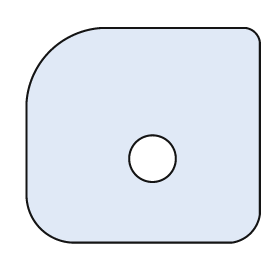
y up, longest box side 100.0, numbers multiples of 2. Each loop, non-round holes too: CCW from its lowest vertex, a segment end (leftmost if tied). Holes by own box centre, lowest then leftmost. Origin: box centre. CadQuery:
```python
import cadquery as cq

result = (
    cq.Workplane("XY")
    .moveTo(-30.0, -46.0)
    .lineTo(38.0, -46.0)
    .threePointArc((46.0, -42.0), (50.0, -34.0))
    .lineTo(50.0, 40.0)
    .threePointArc((48.0, 44.0), (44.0, 46.0))
    .lineTo(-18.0, 46.0)
    .threePointArc((-40.0, 36.0), (-50.0, 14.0))
    .lineTo(-50.0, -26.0)
    .threePointArc((-44.0, -40.0), (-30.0, -46.0))
    .close()
    .moveTo(4.0, -10.0)
    .circle(10.0)
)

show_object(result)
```